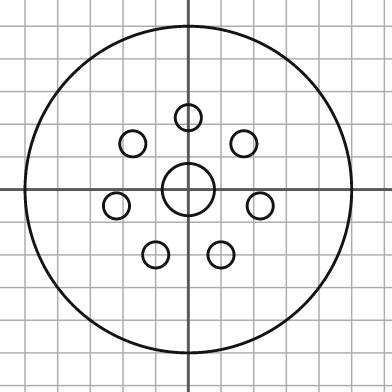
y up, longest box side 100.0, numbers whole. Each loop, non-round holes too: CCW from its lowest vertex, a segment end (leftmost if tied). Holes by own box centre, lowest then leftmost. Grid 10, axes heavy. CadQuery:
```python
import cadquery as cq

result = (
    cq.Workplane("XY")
    .moveTo(0.0, 0.0)
    .circle(50.0)
    .moveTo(-10.0, -20.0)
    .circle(4.0)
    .moveTo(10.0, -20.0)
    .circle(4.0)
    .moveTo(-22.0, -5.0)
    .circle(4.0)
    .moveTo(22.0, -5.0)
    .circle(4.0)
    .moveTo(0.0, 0.0)
    .circle(8.0)
    .moveTo(-17.0, 14.0)
    .circle(4.0)
    .moveTo(17.0, 14.0)
    .circle(4.0)
    .moveTo(0.0, 22.0)
    .circle(4.0)
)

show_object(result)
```